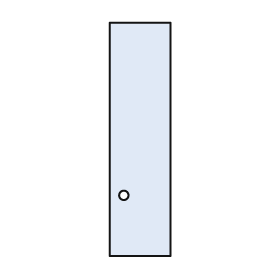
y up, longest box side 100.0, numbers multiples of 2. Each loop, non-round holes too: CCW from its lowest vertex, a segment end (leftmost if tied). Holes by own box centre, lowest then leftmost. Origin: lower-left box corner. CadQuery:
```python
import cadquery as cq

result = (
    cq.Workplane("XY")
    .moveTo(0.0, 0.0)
    .lineTo(26.0, 0.0)
    .lineTo(26.0, 100.0)
    .lineTo(0.0, 100.0)
    .close()
    .moveTo(6.0, 26.0)
    .circle(2.0)
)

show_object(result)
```